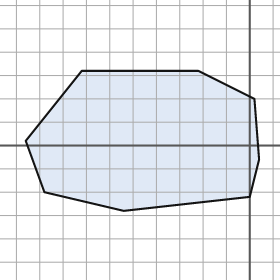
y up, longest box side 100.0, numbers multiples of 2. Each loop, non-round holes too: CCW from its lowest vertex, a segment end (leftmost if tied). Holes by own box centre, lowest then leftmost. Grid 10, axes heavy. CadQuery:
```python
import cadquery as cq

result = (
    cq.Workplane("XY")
    .moveTo(-54.0, -28.0)
    .lineTo(0.0, -22.0)
    .lineTo(4.0, -6.0)
    .lineTo(2.0, 20.0)
    .lineTo(-22.0, 32.0)
    .lineTo(-72.0, 32.0)
    .lineTo(-96.0, 2.0)
    .lineTo(-88.0, -20.0)
    .close()
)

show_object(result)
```